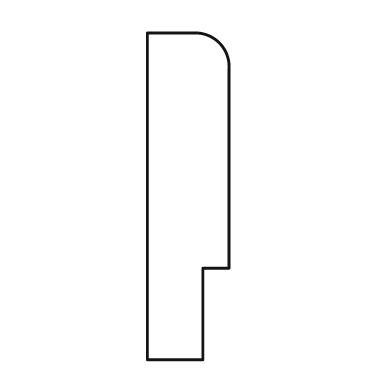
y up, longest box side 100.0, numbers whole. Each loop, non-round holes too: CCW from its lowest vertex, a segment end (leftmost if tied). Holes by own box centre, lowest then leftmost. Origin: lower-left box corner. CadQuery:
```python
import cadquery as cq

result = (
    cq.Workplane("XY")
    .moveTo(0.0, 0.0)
    .lineTo(17.0, 0.0)
    .lineTo(17.0, 28.0)
    .lineTo(25.0, 28.0)
    .lineTo(25.0, 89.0)
    .threePointArc((22.0, 97.0), (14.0, 100.0))
    .lineTo(0.0, 100.0)
    .close()
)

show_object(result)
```